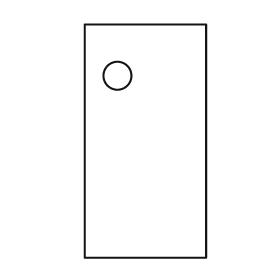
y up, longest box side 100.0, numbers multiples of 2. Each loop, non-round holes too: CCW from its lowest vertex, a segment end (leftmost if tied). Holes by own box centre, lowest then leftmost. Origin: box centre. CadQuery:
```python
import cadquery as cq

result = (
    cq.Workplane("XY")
    .moveTo(-26.0, -50.0)
    .lineTo(26.0, -50.0)
    .lineTo(26.0, 50.0)
    .lineTo(-26.0, 50.0)
    .close()
    .moveTo(-12.0, 28.0)
    .circle(6.0)
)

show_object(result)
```